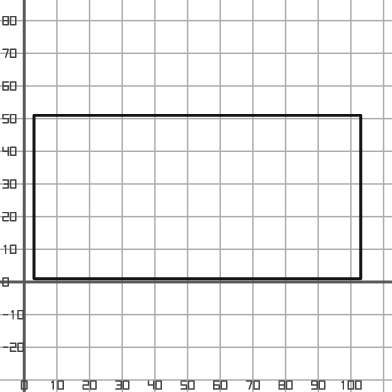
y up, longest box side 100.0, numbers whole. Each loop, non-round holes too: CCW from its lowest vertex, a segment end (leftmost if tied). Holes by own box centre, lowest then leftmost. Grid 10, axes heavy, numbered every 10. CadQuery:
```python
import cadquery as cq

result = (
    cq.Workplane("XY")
    .moveTo(3.0, 1.0)
    .lineTo(103.0, 1.0)
    .lineTo(103.0, 51.0)
    .lineTo(3.0, 51.0)
    .close()
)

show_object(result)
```